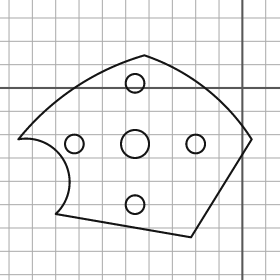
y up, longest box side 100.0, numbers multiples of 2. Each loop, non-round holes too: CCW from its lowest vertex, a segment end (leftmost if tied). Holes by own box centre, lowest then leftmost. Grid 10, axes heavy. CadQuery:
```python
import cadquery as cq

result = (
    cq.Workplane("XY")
    .moveTo(-22.0, -64.0)
    .lineTo(4.0, -22.0)
    .threePointArc((-16.0, 0.0), (-42.0, 14.0))
    .threePointArc((-72.0, 0.0), (-96.0, -22.0))
    .threePointArc((-76.0, -32.0), (-80.0, -54.0))
    .close()
    .moveTo(-46.0, -50.0)
    .circle(4.0)
    .moveTo(-72.0, -24.0)
    .circle(4.0)
    .moveTo(-46.0, -24.0)
    .circle(6.0)
    .moveTo(-20.0, -24.0)
    .circle(4.0)
    .moveTo(-46.0, 2.0)
    .circle(4.0)
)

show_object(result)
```